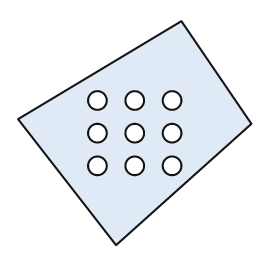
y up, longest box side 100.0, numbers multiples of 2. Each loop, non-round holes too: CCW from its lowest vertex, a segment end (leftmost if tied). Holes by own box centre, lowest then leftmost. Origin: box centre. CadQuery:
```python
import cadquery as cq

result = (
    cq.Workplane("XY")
    .moveTo(-8.0, -48.0)
    .lineTo(50.0, 4.0)
    .lineTo(20.0, 48.0)
    .lineTo(-50.0, 6.0)
    .close()
    .moveTo(-16.0, -14.0)
    .circle(4.0)
    .moveTo(0.0, -14.0)
    .circle(4.0)
    .moveTo(16.0, -14.0)
    .circle(4.0)
    .moveTo(-16.0, 0.0)
    .circle(4.0)
    .moveTo(0.0, 0.0)
    .circle(4.0)
    .moveTo(16.0, 0.0)
    .circle(4.0)
    .moveTo(-16.0, 14.0)
    .circle(4.0)
    .moveTo(0.0, 14.0)
    .circle(4.0)
    .moveTo(16.0, 14.0)
    .circle(4.0)
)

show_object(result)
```